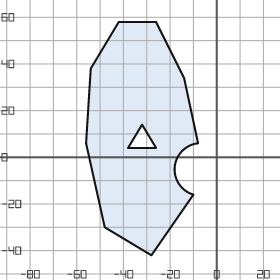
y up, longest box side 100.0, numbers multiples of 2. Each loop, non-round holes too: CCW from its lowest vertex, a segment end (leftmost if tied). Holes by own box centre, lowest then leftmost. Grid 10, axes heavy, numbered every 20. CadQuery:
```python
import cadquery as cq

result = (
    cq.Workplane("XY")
    .moveTo(-28.0, -42.0)
    .lineTo(-10.0, -16.0)
    .threePointArc((-18.0, -4.0), (-8.0, 6.0))
    .lineTo(-14.0, 34.0)
    .lineTo(-26.0, 58.0)
    .lineTo(-42.0, 58.0)
    .lineTo(-54.0, 38.0)
    .lineTo(-56.0, 6.0)
    .lineTo(-48.0, -30.0)
    .close()
    .moveTo(-38.0, 4.0)
    .lineTo(-26.0, 4.0)
    .lineTo(-32.0, 14.0)
    .close()
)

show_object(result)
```